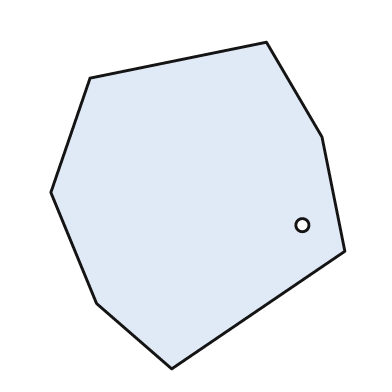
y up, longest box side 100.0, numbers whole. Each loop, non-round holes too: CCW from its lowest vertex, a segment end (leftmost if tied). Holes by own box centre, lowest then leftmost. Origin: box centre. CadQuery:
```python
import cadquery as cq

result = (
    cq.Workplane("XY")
    .moveTo(-8.0, -50.0)
    .lineTo(45.0, -14.0)
    .lineTo(38.0, 21.0)
    .lineTo(21.0, 50.0)
    .lineTo(-33.0, 39.0)
    .lineTo(-45.0, 4.0)
    .lineTo(-31.0, -30.0)
    .close()
    .moveTo(32.0, -6.0)
    .circle(2.0)
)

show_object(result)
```